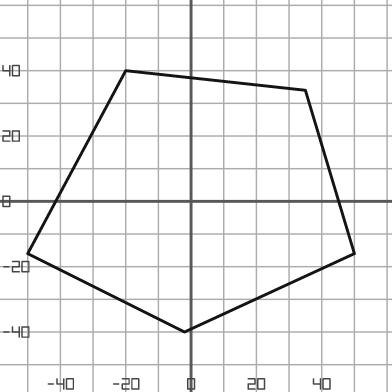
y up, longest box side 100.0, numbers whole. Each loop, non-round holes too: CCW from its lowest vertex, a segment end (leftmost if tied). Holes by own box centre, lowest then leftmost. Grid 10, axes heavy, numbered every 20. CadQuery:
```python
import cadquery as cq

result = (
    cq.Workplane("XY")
    .moveTo(-2.0, -40.0)
    .lineTo(50.0, -16.0)
    .lineTo(35.0, 34.0)
    .lineTo(-20.0, 40.0)
    .lineTo(-50.0, -16.0)
    .close()
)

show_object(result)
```